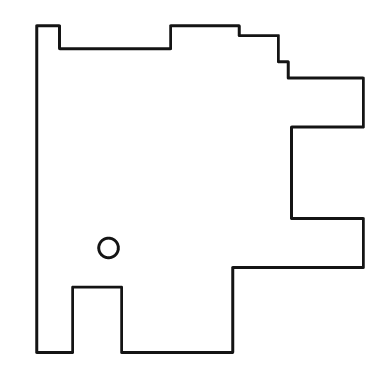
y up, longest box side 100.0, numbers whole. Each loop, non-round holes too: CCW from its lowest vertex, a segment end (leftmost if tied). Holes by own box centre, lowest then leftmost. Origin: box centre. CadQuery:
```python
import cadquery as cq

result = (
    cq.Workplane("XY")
    .moveTo(-50.0, -50.0)
    .lineTo(-39.0, -50.0)
    .lineTo(-39.0, -30.0)
    .lineTo(-24.0, -30.0)
    .lineTo(-24.0, -50.0)
    .lineTo(10.0, -50.0)
    .lineTo(10.0, -24.0)
    .lineTo(50.0, -24.0)
    .lineTo(50.0, -9.0)
    .lineTo(28.0, -9.0)
    .lineTo(28.0, 19.0)
    .lineTo(50.0, 19.0)
    .lineTo(50.0, 34.0)
    .lineTo(27.0, 34.0)
    .lineTo(27.0, 39.0)
    .lineTo(24.0, 39.0)
    .lineTo(24.0, 47.0)
    .lineTo(12.0, 47.0)
    .lineTo(12.0, 50.0)
    .lineTo(-9.0, 50.0)
    .lineTo(-9.0, 43.0)
    .lineTo(-43.0, 43.0)
    .lineTo(-43.0, 50.0)
    .lineTo(-50.0, 50.0)
    .close()
    .moveTo(-28.0, -18.0)
    .circle(3.0)
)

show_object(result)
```